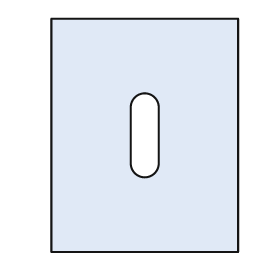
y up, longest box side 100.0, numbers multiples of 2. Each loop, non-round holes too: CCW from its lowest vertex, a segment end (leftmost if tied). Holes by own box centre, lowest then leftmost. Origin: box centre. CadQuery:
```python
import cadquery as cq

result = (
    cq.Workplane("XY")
    .moveTo(-40.0, -50.0)
    .lineTo(40.0, -50.0)
    .lineTo(40.0, 50.0)
    .lineTo(-40.0, 50.0)
    .close()
    .moveTo(-6.0, -12.0)
    .threePointArc((0.0, -18.0), (6.0, -12.0))
    .lineTo(6.0, 12.0)
    .threePointArc((0.0, 18.0), (-6.0, 12.0))
    .close()
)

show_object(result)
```